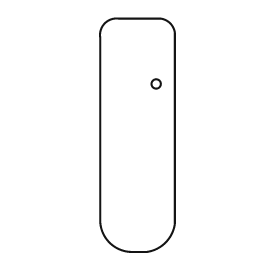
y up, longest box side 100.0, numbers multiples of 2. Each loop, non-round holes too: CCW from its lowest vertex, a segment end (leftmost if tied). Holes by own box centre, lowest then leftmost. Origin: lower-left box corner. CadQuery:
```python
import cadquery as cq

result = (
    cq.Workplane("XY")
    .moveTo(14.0, 0.0)
    .lineTo(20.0, 0.0)
    .threePointArc((28.0, 4.0), (32.0, 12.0))
    .lineTo(32.0, 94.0)
    .threePointArc((30.0, 98.0), (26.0, 100.0))
    .lineTo(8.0, 100.0)
    .threePointArc((2.0, 98.0), (0.0, 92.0))
    .lineTo(0.0, 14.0)
    .threePointArc((4.0, 4.0), (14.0, 0.0))
    .close()
    .moveTo(24.0, 72.0)
    .circle(2.0)
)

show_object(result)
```